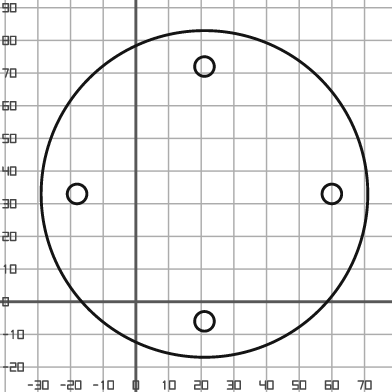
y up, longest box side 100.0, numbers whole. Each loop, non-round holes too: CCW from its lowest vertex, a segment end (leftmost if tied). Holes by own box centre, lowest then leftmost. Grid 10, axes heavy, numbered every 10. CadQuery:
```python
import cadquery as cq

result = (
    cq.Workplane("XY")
    .moveTo(21.0, 33.0)
    .circle(50.0)
    .moveTo(21.0, -6.0)
    .circle(3.0)
    .moveTo(-18.0, 33.0)
    .circle(3.0)
    .moveTo(60.0, 33.0)
    .circle(3.0)
    .moveTo(21.0, 72.0)
    .circle(3.0)
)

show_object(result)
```